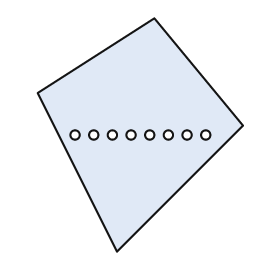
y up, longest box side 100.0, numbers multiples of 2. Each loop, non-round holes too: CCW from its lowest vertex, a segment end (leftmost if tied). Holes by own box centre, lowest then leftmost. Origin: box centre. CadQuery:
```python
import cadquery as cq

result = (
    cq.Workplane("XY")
    .moveTo(-10.0, -50.0)
    .lineTo(44.0, 4.0)
    .lineTo(6.0, 50.0)
    .lineTo(-44.0, 18.0)
    .close()
    .moveTo(-28.0, 0.0)
    .circle(2.0)
    .moveTo(-20.0, 0.0)
    .circle(2.0)
    .moveTo(-12.0, 0.0)
    .circle(2.0)
    .moveTo(-4.0, 0.0)
    .circle(2.0)
    .moveTo(4.0, 0.0)
    .circle(2.0)
    .moveTo(12.0, 0.0)
    .circle(2.0)
    .moveTo(20.0, 0.0)
    .circle(2.0)
    .moveTo(28.0, 0.0)
    .circle(2.0)
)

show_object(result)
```